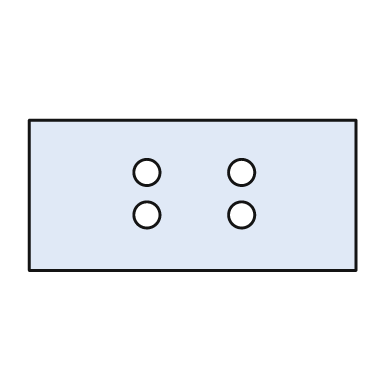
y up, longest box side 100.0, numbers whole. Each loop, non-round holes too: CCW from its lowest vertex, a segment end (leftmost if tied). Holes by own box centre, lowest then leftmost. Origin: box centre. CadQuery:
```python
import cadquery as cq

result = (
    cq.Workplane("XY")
    .moveTo(-50.0, -23.0)
    .lineTo(50.0, -23.0)
    .lineTo(50.0, 23.0)
    .lineTo(-50.0, 23.0)
    .close()
    .moveTo(-14.0, -6.0)
    .circle(4.0)
    .moveTo(15.0, -6.0)
    .circle(4.0)
    .moveTo(-14.0, 7.0)
    .circle(4.0)
    .moveTo(15.0, 7.0)
    .circle(4.0)
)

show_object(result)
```